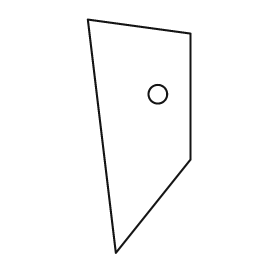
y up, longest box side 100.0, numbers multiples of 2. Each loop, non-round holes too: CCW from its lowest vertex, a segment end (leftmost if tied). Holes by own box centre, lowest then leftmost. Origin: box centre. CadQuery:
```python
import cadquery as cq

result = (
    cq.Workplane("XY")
    .moveTo(-10.0, -50.0)
    .lineTo(22.0, -10.0)
    .lineTo(22.0, 44.0)
    .lineTo(-22.0, 50.0)
    .close()
    .moveTo(8.0, 18.0)
    .circle(4.0)
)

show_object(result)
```